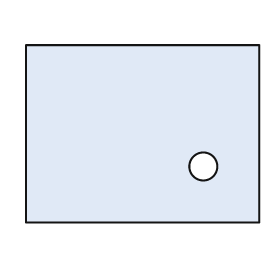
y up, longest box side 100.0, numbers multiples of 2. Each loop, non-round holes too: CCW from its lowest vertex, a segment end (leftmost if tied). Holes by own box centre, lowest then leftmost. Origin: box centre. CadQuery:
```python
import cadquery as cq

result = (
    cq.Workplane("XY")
    .moveTo(-50.0, -38.0)
    .lineTo(50.0, -38.0)
    .lineTo(50.0, 38.0)
    .lineTo(-50.0, 38.0)
    .close()
    .moveTo(26.0, -14.0)
    .circle(6.0)
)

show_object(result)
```